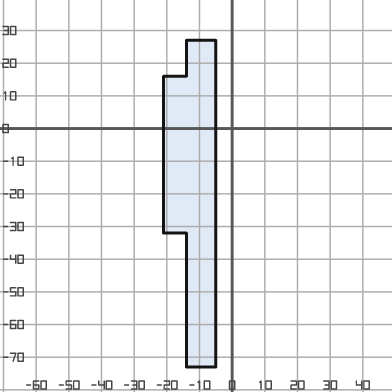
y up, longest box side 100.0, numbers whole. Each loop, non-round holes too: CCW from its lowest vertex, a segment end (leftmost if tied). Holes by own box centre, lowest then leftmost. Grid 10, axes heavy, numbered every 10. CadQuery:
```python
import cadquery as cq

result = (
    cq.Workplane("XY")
    .moveTo(-14.0, -73.0)
    .lineTo(-5.0, -73.0)
    .lineTo(-5.0, 27.0)
    .lineTo(-14.0, 27.0)
    .lineTo(-14.0, 16.0)
    .lineTo(-21.0, 16.0)
    .lineTo(-21.0, -32.0)
    .lineTo(-14.0, -32.0)
    .close()
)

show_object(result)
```